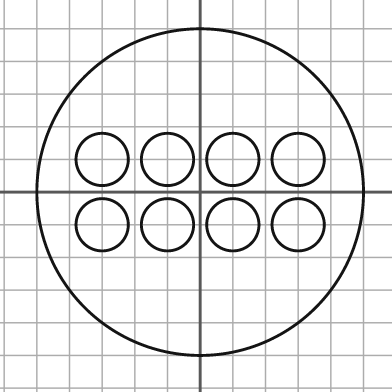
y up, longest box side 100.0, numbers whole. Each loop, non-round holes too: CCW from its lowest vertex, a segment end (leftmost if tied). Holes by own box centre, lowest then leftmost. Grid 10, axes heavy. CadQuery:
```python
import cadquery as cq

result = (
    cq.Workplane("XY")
    .moveTo(0.0, 0.0)
    .circle(50.0)
    .moveTo(-30.0, -10.0)
    .circle(8.0)
    .moveTo(-10.0, -10.0)
    .circle(8.0)
    .moveTo(10.0, -10.0)
    .circle(8.0)
    .moveTo(30.0, -10.0)
    .circle(8.0)
    .moveTo(-30.0, 10.0)
    .circle(8.0)
    .moveTo(-10.0, 10.0)
    .circle(8.0)
    .moveTo(10.0, 10.0)
    .circle(8.0)
    .moveTo(30.0, 10.0)
    .circle(8.0)
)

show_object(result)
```